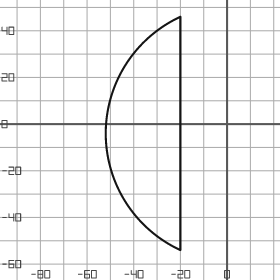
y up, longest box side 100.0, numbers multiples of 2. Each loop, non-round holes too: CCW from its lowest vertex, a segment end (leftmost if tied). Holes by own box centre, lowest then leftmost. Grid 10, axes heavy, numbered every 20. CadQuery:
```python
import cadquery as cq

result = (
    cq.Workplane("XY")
    .moveTo(-20.0, -54.0)
    .lineTo(-20.0, 46.0)
    .threePointArc((-52.0, -4.0), (-20.0, -54.0))
    .close()
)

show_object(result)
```